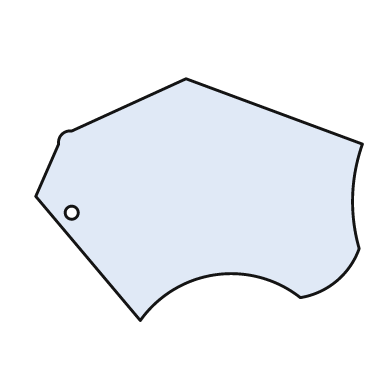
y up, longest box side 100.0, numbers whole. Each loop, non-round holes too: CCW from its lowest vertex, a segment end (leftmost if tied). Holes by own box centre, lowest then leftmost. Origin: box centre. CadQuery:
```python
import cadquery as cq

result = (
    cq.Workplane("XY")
    .moveTo(-18.0, -37.0)
    .threePointArc((5.0, -23.0), (31.0, -30.0))
    .threePointArc((42.0, -25.0), (49.0, -15.0))
    .threePointArc((47.0, 1.0), (50.0, 17.0))
    .lineTo(-4.0, 37.0)
    .lineTo(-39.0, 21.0)
    .threePointArc((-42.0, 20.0), (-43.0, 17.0))
    .lineTo(-50.0, 1.0)
    .close()
    .moveTo(-39.0, -4.0)
    .circle(2.0)
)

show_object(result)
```